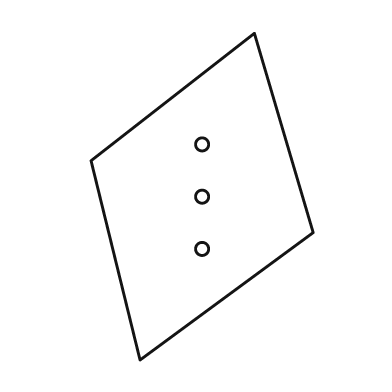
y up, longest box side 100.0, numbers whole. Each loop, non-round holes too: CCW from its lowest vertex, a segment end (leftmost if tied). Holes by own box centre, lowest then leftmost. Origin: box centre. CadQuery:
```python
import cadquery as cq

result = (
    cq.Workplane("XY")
    .moveTo(-19.0, -50.0)
    .lineTo(34.0, -11.0)
    .lineTo(16.0, 50.0)
    .lineTo(-34.0, 11.0)
    .close()
    .moveTo(0.0, -16.0)
    .circle(2.0)
    .moveTo(0.0, 0.0)
    .circle(2.0)
    .moveTo(0.0, 16.0)
    .circle(2.0)
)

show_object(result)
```